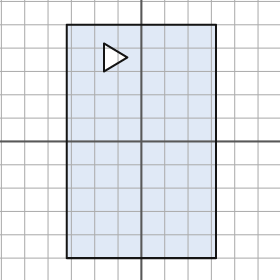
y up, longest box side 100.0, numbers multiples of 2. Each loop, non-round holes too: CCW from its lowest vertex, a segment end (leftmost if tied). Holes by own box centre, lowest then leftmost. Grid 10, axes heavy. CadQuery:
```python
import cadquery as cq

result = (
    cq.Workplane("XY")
    .moveTo(-32.0, -50.0)
    .lineTo(32.0, -50.0)
    .lineTo(32.0, 50.0)
    .lineTo(-32.0, 50.0)
    .close()
    .moveTo(-16.0, 30.0)
    .lineTo(-6.0, 36.0)
    .lineTo(-16.0, 42.0)
    .close()
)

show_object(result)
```